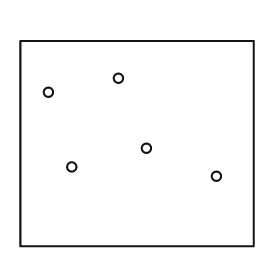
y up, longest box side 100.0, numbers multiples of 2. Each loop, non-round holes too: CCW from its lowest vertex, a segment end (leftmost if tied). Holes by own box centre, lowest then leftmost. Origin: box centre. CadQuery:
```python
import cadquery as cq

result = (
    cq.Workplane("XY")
    .moveTo(-50.0, -44.0)
    .lineTo(50.0, -44.0)
    .lineTo(50.0, 44.0)
    .lineTo(-50.0, 44.0)
    .close()
    .moveTo(34.0, -14.0)
    .circle(2.0)
    .moveTo(-28.0, -10.0)
    .circle(2.0)
    .moveTo(4.0, -2.0)
    .circle(2.0)
    .moveTo(-38.0, 22.0)
    .circle(2.0)
    .moveTo(-8.0, 28.0)
    .circle(2.0)
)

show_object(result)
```